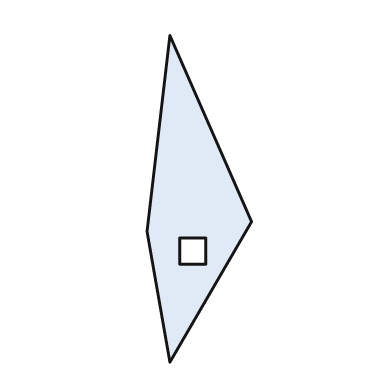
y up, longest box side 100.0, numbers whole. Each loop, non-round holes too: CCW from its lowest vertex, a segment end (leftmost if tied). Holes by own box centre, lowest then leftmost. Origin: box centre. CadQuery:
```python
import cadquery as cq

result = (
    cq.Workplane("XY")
    .moveTo(-9.0, -50.0)
    .lineTo(16.0, -7.0)
    .lineTo(-9.0, 50.0)
    .lineTo(-16.0, -10.0)
    .close()
    .moveTo(-6.0, -20.0)
    .lineTo(2.0, -20.0)
    .lineTo(2.0, -12.0)
    .lineTo(-6.0, -12.0)
    .close()
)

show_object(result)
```